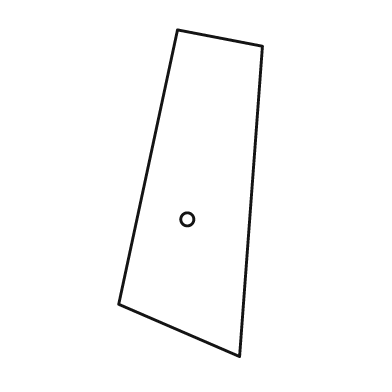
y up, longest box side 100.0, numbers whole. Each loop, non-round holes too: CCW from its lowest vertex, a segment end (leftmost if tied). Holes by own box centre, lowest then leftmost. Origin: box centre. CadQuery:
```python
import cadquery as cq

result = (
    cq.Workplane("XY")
    .moveTo(15.0, -50.0)
    .lineTo(22.0, 45.0)
    .lineTo(-4.0, 50.0)
    .lineTo(-22.0, -34.0)
    .close()
    .moveTo(-1.0, -8.0)
    .circle(2.0)
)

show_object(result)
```